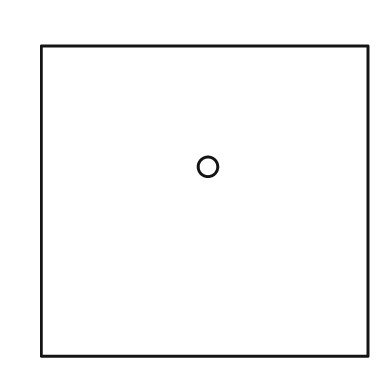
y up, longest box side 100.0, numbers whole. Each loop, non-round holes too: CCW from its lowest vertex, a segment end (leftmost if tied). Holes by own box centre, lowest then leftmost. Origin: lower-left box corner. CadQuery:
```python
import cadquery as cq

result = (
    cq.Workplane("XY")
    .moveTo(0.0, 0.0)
    .lineTo(100.0, 0.0)
    .lineTo(100.0, 95.0)
    .lineTo(0.0, 95.0)
    .close()
    .moveTo(51.0, 58.0)
    .circle(3.0)
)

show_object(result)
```